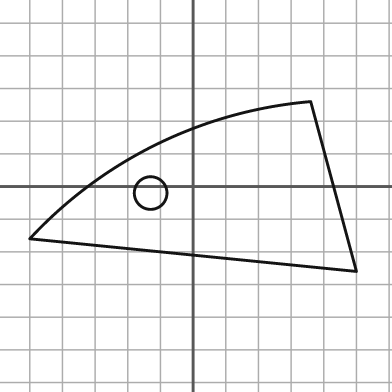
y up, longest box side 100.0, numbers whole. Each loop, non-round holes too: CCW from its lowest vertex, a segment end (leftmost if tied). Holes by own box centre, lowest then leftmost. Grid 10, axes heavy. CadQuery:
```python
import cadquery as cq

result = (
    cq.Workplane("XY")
    .moveTo(50.0, -26.0)
    .lineTo(36.0, 26.0)
    .threePointArc((-11.0, 13.0), (-50.0, -16.0))
    .close()
    .moveTo(-13.0, -2.0)
    .circle(5.0)
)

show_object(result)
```